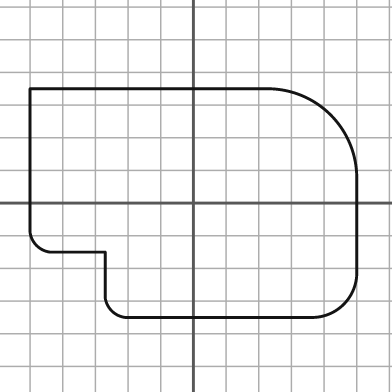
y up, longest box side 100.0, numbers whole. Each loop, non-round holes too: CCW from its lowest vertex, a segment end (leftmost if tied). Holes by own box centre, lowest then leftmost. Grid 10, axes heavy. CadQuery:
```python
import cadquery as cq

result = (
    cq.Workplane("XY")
    .moveTo(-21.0, -35.0)
    .lineTo(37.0, -35.0)
    .threePointArc((46.0, -31.0), (50.0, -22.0))
    .lineTo(50.0, 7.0)
    .threePointArc((42.0, 27.0), (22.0, 35.0))
    .lineTo(-50.0, 35.0)
    .lineTo(-50.0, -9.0)
    .threePointArc((-48.0, -13.0), (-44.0, -15.0))
    .lineTo(-27.0, -15.0)
    .lineTo(-27.0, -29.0)
    .threePointArc((-25.0, -33.0), (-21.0, -35.0))
    .close()
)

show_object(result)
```